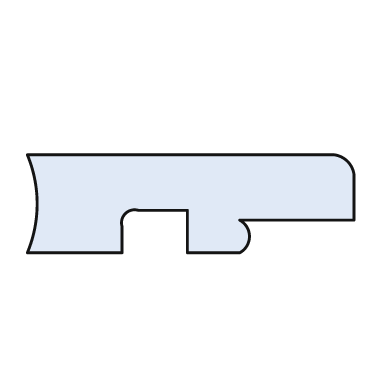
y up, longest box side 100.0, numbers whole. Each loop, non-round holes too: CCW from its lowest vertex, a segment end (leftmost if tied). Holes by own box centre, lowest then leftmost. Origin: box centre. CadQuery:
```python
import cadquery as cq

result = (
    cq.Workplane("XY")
    .moveTo(-50.0, -15.0)
    .lineTo(-21.0, -15.0)
    .lineTo(-21.0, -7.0)
    .threePointArc((-20.0, -3.0), (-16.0, -2.0))
    .lineTo(-1.0, -2.0)
    .lineTo(-1.0, -15.0)
    .lineTo(15.0, -15.0)
    .threePointArc((18.0, -10.0), (15.0, -5.0))
    .lineTo(50.0, -5.0)
    .lineTo(50.0, 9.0)
    .threePointArc((48.0, 13.0), (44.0, 15.0))
    .lineTo(-50.0, 15.0)
    .threePointArc((-47.0, 0.0), (-50.0, -15.0))
    .close()
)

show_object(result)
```